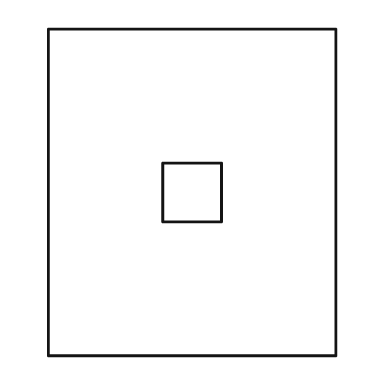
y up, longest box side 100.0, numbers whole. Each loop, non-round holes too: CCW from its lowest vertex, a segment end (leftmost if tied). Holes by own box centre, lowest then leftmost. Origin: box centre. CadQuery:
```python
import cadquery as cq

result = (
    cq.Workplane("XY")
    .moveTo(-44.0, -50.0)
    .lineTo(44.0, -50.0)
    .lineTo(44.0, 50.0)
    .lineTo(-44.0, 50.0)
    .close()
    .moveTo(-9.0, -9.0)
    .lineTo(9.0, -9.0)
    .lineTo(9.0, 9.0)
    .lineTo(-9.0, 9.0)
    .close()
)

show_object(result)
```